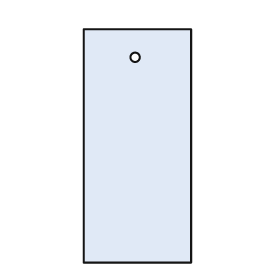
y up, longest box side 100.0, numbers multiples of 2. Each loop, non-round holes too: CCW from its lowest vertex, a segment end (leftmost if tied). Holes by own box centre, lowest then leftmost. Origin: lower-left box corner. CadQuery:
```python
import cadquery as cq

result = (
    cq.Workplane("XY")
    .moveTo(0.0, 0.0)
    .lineTo(46.0, 0.0)
    .lineTo(46.0, 100.0)
    .lineTo(0.0, 100.0)
    .close()
    .moveTo(22.0, 88.0)
    .circle(2.0)
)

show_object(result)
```